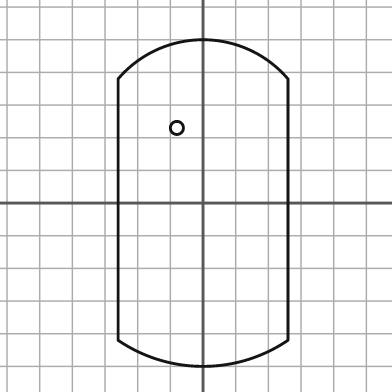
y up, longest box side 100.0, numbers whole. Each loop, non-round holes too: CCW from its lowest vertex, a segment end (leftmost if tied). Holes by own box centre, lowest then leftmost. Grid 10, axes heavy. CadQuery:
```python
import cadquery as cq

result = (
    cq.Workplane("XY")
    .moveTo(-26.0, -42.0)
    .threePointArc((0.0, -50.0), (26.0, -42.0))
    .lineTo(26.0, 38.0)
    .threePointArc((0.0, 50.0), (-26.0, 38.0))
    .close()
    .moveTo(-8.0, 23.0)
    .circle(2.0)
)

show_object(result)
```